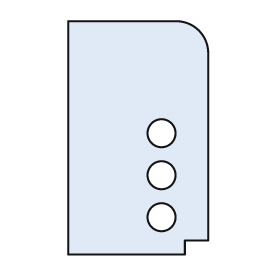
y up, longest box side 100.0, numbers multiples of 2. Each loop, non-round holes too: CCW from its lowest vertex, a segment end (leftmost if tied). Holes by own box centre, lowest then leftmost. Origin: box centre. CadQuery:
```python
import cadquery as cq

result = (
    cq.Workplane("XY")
    .moveTo(-30.0, -50.0)
    .lineTo(20.0, -50.0)
    .lineTo(20.0, -44.0)
    .lineTo(30.0, -44.0)
    .lineTo(30.0, 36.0)
    .threePointArc((26.0, 46.0), (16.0, 50.0))
    .lineTo(-30.0, 50.0)
    .close()
    .moveTo(10.0, -34.0)
    .circle(6.0)
    .moveTo(10.0, -16.0)
    .circle(6.0)
    .moveTo(10.0, 2.0)
    .circle(6.0)
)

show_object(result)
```